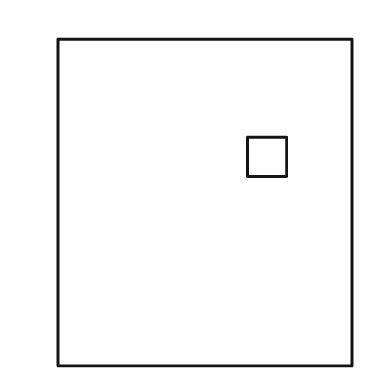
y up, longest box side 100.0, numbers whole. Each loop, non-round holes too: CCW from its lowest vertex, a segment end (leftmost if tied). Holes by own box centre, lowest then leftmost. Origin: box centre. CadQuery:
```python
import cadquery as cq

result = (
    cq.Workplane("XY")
    .moveTo(-45.0, -50.0)
    .lineTo(45.0, -50.0)
    .lineTo(45.0, 50.0)
    .lineTo(-45.0, 50.0)
    .close()
    .moveTo(13.0, 8.0)
    .lineTo(25.0, 8.0)
    .lineTo(25.0, 20.0)
    .lineTo(13.0, 20.0)
    .close()
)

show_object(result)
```